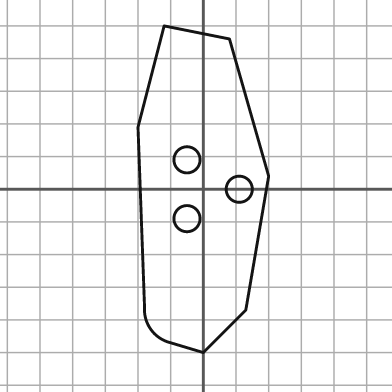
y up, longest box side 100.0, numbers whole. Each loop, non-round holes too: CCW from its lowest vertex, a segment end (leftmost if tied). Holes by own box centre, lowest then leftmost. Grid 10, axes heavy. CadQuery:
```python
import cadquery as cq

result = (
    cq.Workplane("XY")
    .moveTo(0.0, -50.0)
    .lineTo(13.0, -37.0)
    .lineTo(20.0, 4.0)
    .lineTo(8.0, 46.0)
    .lineTo(-12.0, 50.0)
    .lineTo(-20.0, 19.0)
    .lineTo(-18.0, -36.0)
    .threePointArc((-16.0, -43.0), (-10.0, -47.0))
    .close()
    .moveTo(-5.0, -9.0)
    .circle(4.0)
    .moveTo(11.0, 0.0)
    .circle(4.0)
    .moveTo(-5.0, 9.0)
    .circle(4.0)
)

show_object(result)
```